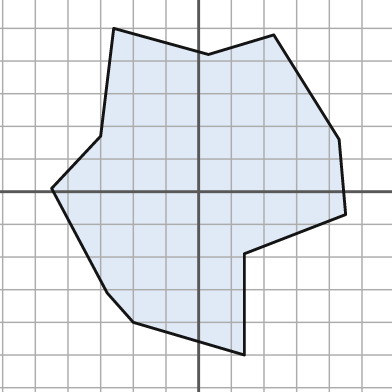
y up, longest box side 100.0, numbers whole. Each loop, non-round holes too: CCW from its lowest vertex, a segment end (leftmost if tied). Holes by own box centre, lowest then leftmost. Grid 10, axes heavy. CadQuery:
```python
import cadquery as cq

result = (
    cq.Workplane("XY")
    .moveTo(14.0, -50.0)
    .lineTo(14.0, -19.0)
    .lineTo(45.0, -7.0)
    .lineTo(43.0, 16.0)
    .lineTo(23.0, 48.0)
    .lineTo(3.0, 42.0)
    .lineTo(-26.0, 50.0)
    .lineTo(-30.0, 17.0)
    .lineTo(-45.0, 1.0)
    .lineTo(-28.0, -31.0)
    .lineTo(-20.0, -40.0)
    .close()
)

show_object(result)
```